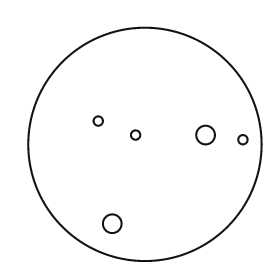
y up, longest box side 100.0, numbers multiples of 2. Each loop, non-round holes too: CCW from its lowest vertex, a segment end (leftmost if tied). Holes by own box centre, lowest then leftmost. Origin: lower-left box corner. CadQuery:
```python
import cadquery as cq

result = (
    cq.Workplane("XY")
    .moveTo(50.0, 50.0)
    .circle(50.0)
    .moveTo(36.0, 16.0)
    .circle(4.0)
    .moveTo(92.0, 52.0)
    .circle(2.0)
    .moveTo(46.0, 54.0)
    .circle(2.0)
    .moveTo(76.0, 54.0)
    .circle(4.0)
    .moveTo(30.0, 60.0)
    .circle(2.0)
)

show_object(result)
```